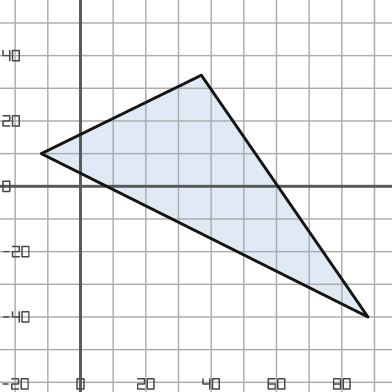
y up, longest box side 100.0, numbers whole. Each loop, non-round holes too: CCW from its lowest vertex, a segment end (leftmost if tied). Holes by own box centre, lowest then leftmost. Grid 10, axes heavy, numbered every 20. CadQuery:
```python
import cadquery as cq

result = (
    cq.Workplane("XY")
    .moveTo(88.0, -40.0)
    .lineTo(37.0, 34.0)
    .lineTo(-12.0, 10.0)
    .close()
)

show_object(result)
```